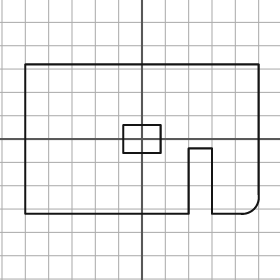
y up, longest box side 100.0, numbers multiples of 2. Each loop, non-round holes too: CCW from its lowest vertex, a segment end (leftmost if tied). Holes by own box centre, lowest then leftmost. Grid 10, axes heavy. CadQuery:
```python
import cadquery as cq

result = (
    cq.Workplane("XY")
    .moveTo(-50.0, -32.0)
    .lineTo(20.0, -32.0)
    .lineTo(20.0, -4.0)
    .lineTo(30.0, -4.0)
    .lineTo(30.0, -32.0)
    .lineTo(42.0, -32.0)
    .threePointArc((48.0, -30.0), (50.0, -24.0))
    .lineTo(50.0, 32.0)
    .lineTo(-50.0, 32.0)
    .close()
    .moveTo(-8.0, -6.0)
    .lineTo(8.0, -6.0)
    .lineTo(8.0, 6.0)
    .lineTo(-8.0, 6.0)
    .close()
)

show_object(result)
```